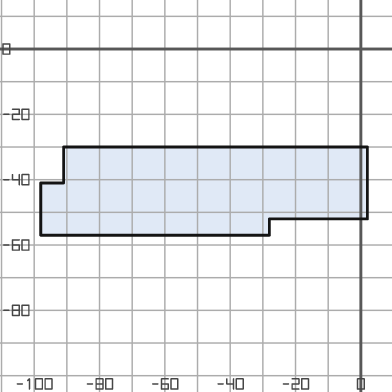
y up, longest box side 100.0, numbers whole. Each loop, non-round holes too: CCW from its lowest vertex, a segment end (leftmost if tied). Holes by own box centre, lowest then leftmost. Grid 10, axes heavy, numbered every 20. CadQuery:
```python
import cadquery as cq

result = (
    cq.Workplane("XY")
    .moveTo(-98.0, -57.0)
    .lineTo(-28.0, -57.0)
    .lineTo(-28.0, -52.0)
    .lineTo(2.0, -52.0)
    .lineTo(2.0, -30.0)
    .lineTo(-91.0, -30.0)
    .lineTo(-91.0, -41.0)
    .lineTo(-98.0, -41.0)
    .close()
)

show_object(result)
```